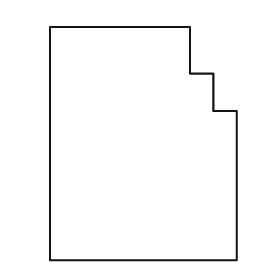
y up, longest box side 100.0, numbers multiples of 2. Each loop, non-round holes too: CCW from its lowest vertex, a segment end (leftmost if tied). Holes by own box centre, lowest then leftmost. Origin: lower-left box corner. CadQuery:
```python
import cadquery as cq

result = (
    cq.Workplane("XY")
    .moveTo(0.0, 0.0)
    .lineTo(80.0, 0.0)
    .lineTo(80.0, 64.0)
    .lineTo(70.0, 64.0)
    .lineTo(70.0, 80.0)
    .lineTo(60.0, 80.0)
    .lineTo(60.0, 100.0)
    .lineTo(0.0, 100.0)
    .close()
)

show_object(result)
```